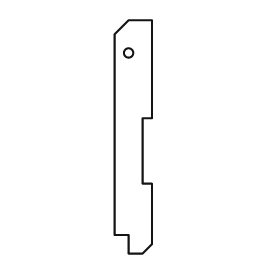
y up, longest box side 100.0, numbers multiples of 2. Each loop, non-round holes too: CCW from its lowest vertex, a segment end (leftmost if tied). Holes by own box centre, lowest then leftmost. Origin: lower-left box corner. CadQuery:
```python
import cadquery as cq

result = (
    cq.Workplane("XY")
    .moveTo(6.0, 0.0)
    .lineTo(12.0, 0.0)
    .lineTo(16.0, 4.0)
    .lineTo(16.0, 30.0)
    .lineTo(12.0, 30.0)
    .lineTo(12.0, 58.0)
    .lineTo(16.0, 58.0)
    .lineTo(16.0, 100.0)
    .lineTo(6.0, 100.0)
    .lineTo(0.0, 94.0)
    .lineTo(0.0, 8.0)
    .lineTo(6.0, 8.0)
    .close()
    .moveTo(6.0, 86.0)
    .circle(2.0)
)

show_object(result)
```